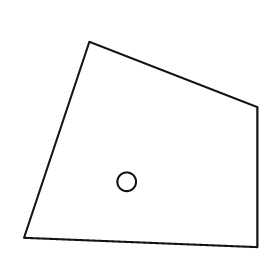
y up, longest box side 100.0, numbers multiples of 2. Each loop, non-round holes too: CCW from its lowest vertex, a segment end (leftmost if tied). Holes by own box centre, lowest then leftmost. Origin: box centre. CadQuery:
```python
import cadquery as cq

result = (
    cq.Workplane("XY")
    .moveTo(50.0, -44.0)
    .lineTo(50.0, 16.0)
    .lineTo(-22.0, 44.0)
    .lineTo(-50.0, -40.0)
    .close()
    .moveTo(-6.0, -16.0)
    .circle(4.0)
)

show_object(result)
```